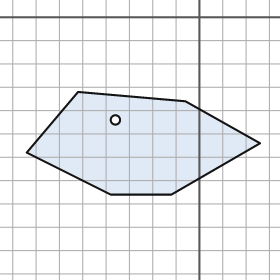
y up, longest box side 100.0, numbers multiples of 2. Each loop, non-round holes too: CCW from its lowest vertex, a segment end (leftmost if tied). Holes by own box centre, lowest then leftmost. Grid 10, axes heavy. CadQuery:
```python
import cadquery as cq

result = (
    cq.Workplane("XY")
    .moveTo(-38.0, -76.0)
    .lineTo(-12.0, -76.0)
    .lineTo(26.0, -54.0)
    .lineTo(-6.0, -36.0)
    .lineTo(-52.0, -32.0)
    .lineTo(-74.0, -58.0)
    .close()
    .moveTo(-36.0, -44.0)
    .circle(2.0)
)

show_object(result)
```